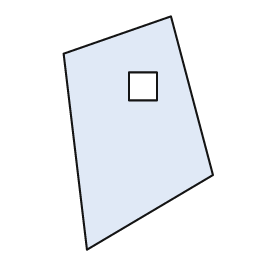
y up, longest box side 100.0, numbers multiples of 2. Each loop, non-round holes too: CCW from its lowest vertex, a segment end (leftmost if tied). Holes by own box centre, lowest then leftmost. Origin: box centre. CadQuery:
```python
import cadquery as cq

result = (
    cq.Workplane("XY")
    .moveTo(-22.0, -50.0)
    .lineTo(32.0, -18.0)
    .lineTo(14.0, 50.0)
    .lineTo(-32.0, 34.0)
    .close()
    .moveTo(-4.0, 14.0)
    .lineTo(8.0, 14.0)
    .lineTo(8.0, 26.0)
    .lineTo(-4.0, 26.0)
    .close()
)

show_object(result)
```